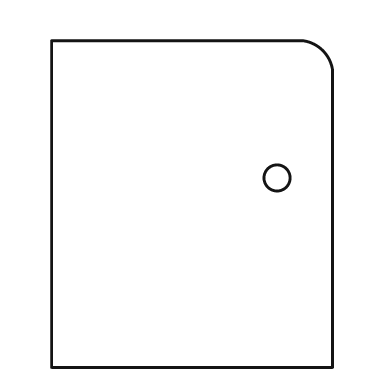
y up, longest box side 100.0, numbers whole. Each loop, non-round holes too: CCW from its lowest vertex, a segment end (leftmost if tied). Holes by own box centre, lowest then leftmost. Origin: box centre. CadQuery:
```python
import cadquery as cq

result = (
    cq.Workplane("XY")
    .moveTo(-43.0, -50.0)
    .lineTo(43.0, -50.0)
    .lineTo(43.0, 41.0)
    .threePointArc((40.0, 47.0), (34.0, 50.0))
    .lineTo(-43.0, 50.0)
    .close()
    .moveTo(26.0, 8.0)
    .circle(4.0)
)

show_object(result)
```